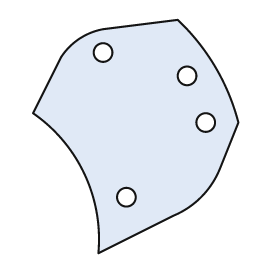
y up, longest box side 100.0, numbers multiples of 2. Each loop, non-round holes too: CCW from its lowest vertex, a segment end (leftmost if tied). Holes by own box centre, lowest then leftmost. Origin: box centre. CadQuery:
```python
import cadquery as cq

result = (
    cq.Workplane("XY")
    .moveTo(-16.0, -50.0)
    .lineTo(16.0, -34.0)
    .threePointArc((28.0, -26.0), (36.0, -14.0))
    .lineTo(44.0, 6.0)
    .threePointArc((34.0, 30.0), (18.0, 50.0))
    .lineTo(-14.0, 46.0)
    .threePointArc((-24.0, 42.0), (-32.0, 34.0))
    .lineTo(-44.0, 10.0)
    .threePointArc((-22.0, -16.0), (-16.0, -50.0))
    .close()
    .moveTo(-4.0, -26.0)
    .circle(4.0)
    .moveTo(30.0, 6.0)
    .circle(4.0)
    .moveTo(22.0, 26.0)
    .circle(4.0)
    .moveTo(-14.0, 36.0)
    .circle(4.0)
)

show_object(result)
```